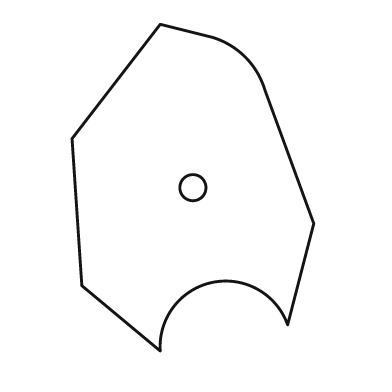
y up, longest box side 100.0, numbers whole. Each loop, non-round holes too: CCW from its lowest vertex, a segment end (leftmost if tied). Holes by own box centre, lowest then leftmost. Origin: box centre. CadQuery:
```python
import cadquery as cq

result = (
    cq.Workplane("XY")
    .moveTo(-10.0, -50.0)
    .threePointArc((6.0, -29.0), (29.0, -42.0))
    .lineTo(37.0, -11.0)
    .lineTo(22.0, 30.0)
    .threePointArc((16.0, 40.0), (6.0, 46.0))
    .lineTo(-10.0, 50.0)
    .lineTo(-37.0, 15.0)
    .lineTo(-34.0, -30.0)
    .close()
    .moveTo(0.0, 0.0)
    .circle(4.0)
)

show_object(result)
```